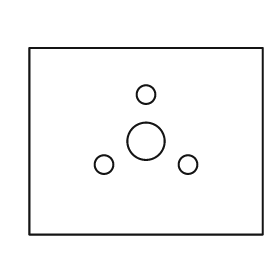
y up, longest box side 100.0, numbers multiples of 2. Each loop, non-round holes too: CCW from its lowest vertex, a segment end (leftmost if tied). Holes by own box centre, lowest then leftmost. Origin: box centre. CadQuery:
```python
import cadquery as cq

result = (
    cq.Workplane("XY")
    .moveTo(-50.0, -40.0)
    .lineTo(50.0, -40.0)
    .lineTo(50.0, 40.0)
    .lineTo(-50.0, 40.0)
    .close()
    .moveTo(-18.0, -10.0)
    .circle(4.0)
    .moveTo(18.0, -10.0)
    .circle(4.0)
    .moveTo(0.0, 0.0)
    .circle(8.0)
    .moveTo(0.0, 20.0)
    .circle(4.0)
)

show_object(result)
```